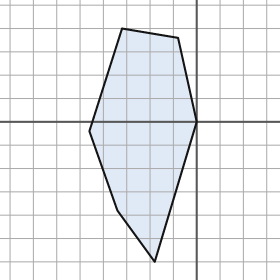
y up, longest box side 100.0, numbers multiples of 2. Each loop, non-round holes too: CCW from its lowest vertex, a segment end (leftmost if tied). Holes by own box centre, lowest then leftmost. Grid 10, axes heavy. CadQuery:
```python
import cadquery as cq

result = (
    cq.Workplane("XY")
    .moveTo(-18.0, -60.0)
    .lineTo(0.0, 0.0)
    .lineTo(-8.0, 36.0)
    .lineTo(-32.0, 40.0)
    .lineTo(-46.0, -4.0)
    .lineTo(-34.0, -38.0)
    .close()
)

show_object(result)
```